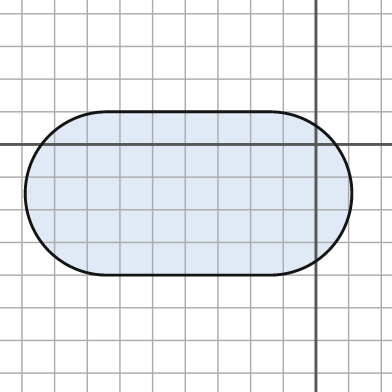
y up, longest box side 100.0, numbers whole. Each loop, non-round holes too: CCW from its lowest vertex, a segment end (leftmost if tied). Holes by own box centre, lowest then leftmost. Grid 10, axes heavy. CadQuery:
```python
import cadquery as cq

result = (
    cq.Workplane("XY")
    .moveTo(-64.0, -40.0)
    .lineTo(-14.0, -40.0)
    .threePointArc((11.0, -15.0), (-14.0, 10.0))
    .lineTo(-64.0, 10.0)
    .threePointArc((-89.0, -15.0), (-64.0, -40.0))
    .close()
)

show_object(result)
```